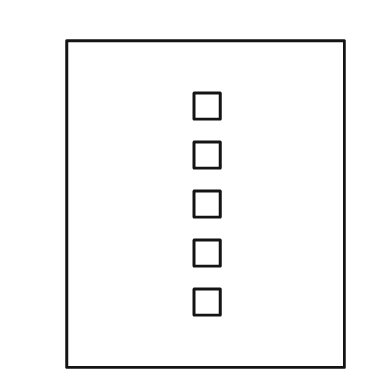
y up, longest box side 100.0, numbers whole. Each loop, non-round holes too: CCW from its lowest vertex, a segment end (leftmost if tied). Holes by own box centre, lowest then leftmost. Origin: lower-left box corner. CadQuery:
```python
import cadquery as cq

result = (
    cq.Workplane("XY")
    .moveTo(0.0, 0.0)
    .lineTo(85.0, 0.0)
    .lineTo(85.0, 100.0)
    .lineTo(0.0, 100.0)
    .close()
    .moveTo(39.0, 16.0)
    .lineTo(47.0, 16.0)
    .lineTo(47.0, 24.0)
    .lineTo(39.0, 24.0)
    .close()
    .moveTo(39.0, 31.0)
    .lineTo(47.0, 31.0)
    .lineTo(47.0, 39.0)
    .lineTo(39.0, 39.0)
    .close()
    .moveTo(39.0, 46.0)
    .lineTo(47.0, 46.0)
    .lineTo(47.0, 54.0)
    .lineTo(39.0, 54.0)
    .close()
    .moveTo(39.0, 61.0)
    .lineTo(47.0, 61.0)
    .lineTo(47.0, 69.0)
    .lineTo(39.0, 69.0)
    .close()
    .moveTo(39.0, 76.0)
    .lineTo(47.0, 76.0)
    .lineTo(47.0, 84.0)
    .lineTo(39.0, 84.0)
    .close()
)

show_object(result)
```